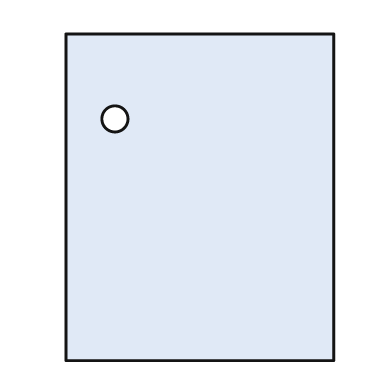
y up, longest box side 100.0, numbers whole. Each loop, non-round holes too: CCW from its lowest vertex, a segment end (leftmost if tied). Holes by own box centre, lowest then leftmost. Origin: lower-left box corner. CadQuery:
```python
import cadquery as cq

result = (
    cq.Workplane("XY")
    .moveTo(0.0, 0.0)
    .lineTo(82.0, 0.0)
    .lineTo(82.0, 100.0)
    .lineTo(0.0, 100.0)
    .close()
    .moveTo(15.0, 74.0)
    .circle(4.0)
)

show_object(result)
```